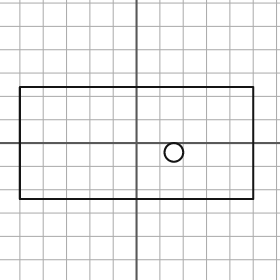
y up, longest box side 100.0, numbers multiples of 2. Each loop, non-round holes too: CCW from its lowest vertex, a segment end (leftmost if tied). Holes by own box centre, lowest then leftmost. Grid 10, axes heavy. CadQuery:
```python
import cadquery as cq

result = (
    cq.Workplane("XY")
    .moveTo(-50.0, -24.0)
    .lineTo(50.0, -24.0)
    .lineTo(50.0, 24.0)
    .lineTo(-50.0, 24.0)
    .close()
    .moveTo(16.0, -4.0)
    .circle(4.0)
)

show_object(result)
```